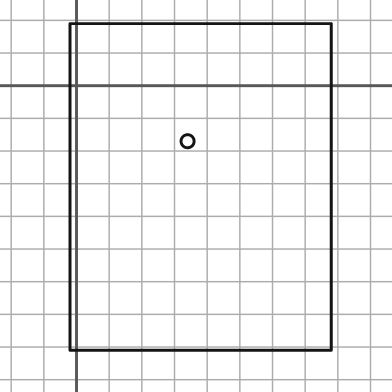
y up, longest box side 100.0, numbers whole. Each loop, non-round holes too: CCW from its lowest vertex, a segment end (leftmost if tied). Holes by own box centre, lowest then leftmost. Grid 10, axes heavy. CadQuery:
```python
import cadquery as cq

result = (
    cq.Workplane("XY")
    .moveTo(-2.0, -81.0)
    .lineTo(78.0, -81.0)
    .lineTo(78.0, 19.0)
    .lineTo(-2.0, 19.0)
    .close()
    .moveTo(34.0, -17.0)
    .circle(2.0)
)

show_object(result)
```